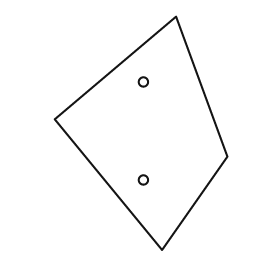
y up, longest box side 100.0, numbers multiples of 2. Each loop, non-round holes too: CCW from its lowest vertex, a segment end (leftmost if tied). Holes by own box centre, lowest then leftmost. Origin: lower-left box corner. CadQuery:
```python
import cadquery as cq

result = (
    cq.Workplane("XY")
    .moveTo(46.0, 0.0)
    .lineTo(74.0, 40.0)
    .lineTo(52.0, 100.0)
    .lineTo(0.0, 56.0)
    .close()
    .moveTo(38.0, 30.0)
    .circle(2.0)
    .moveTo(38.0, 72.0)
    .circle(2.0)
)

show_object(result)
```